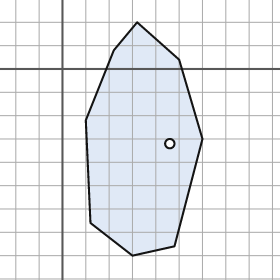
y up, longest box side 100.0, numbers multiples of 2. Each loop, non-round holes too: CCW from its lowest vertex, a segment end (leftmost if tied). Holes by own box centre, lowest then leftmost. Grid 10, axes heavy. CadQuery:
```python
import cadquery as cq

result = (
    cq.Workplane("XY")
    .moveTo(30.0, -80.0)
    .lineTo(48.0, -76.0)
    .lineTo(60.0, -30.0)
    .lineTo(50.0, 4.0)
    .lineTo(32.0, 20.0)
    .lineTo(22.0, 8.0)
    .lineTo(10.0, -22.0)
    .lineTo(12.0, -66.0)
    .close()
    .moveTo(46.0, -32.0)
    .circle(2.0)
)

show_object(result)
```